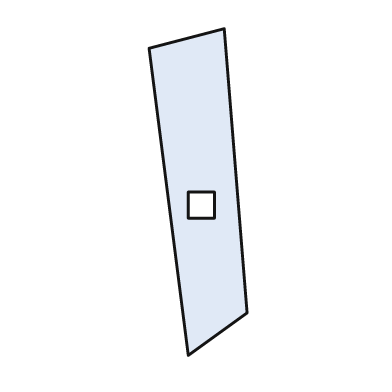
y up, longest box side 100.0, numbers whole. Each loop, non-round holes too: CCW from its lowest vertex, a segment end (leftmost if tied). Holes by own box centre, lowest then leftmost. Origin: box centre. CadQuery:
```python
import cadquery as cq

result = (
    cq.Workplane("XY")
    .moveTo(-3.0, -50.0)
    .lineTo(15.0, -37.0)
    .lineTo(8.0, 50.0)
    .lineTo(-15.0, 44.0)
    .close()
    .moveTo(-3.0, -8.0)
    .lineTo(5.0, -8.0)
    .lineTo(5.0, 0.0)
    .lineTo(-3.0, 0.0)
    .close()
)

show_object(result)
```